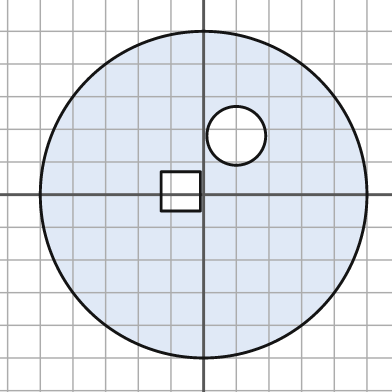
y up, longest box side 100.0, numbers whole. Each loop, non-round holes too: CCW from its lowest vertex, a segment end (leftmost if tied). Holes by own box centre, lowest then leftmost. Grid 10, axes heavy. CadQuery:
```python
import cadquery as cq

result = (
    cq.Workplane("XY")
    .moveTo(0.0, 0.0)
    .circle(50.0)
    .moveTo(-13.0, -5.0)
    .lineTo(-1.0, -5.0)
    .lineTo(-1.0, 7.0)
    .lineTo(-13.0, 7.0)
    .close()
    .moveTo(10.0, 18.0)
    .circle(9.0)
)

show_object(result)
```